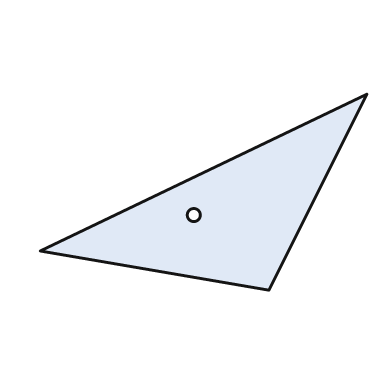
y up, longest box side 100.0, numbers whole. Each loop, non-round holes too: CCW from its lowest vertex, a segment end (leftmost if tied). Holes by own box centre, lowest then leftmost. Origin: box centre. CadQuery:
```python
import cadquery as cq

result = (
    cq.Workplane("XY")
    .moveTo(20.0, -30.0)
    .lineTo(50.0, 30.0)
    .lineTo(-50.0, -18.0)
    .close()
    .moveTo(-3.0, -7.0)
    .circle(2.0)
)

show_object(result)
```